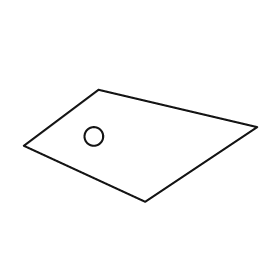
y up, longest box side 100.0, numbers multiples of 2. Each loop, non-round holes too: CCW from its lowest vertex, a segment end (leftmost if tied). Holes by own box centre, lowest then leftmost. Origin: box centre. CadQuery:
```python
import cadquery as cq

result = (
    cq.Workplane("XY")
    .moveTo(2.0, -24.0)
    .lineTo(50.0, 8.0)
    .lineTo(-18.0, 24.0)
    .lineTo(-50.0, 0.0)
    .close()
    .moveTo(-20.0, 4.0)
    .circle(4.0)
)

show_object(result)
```